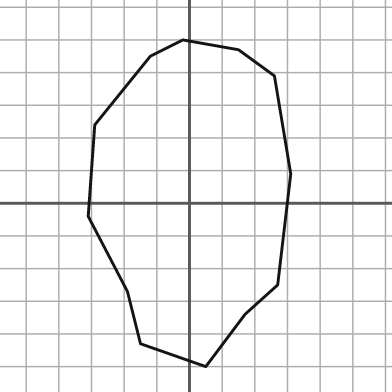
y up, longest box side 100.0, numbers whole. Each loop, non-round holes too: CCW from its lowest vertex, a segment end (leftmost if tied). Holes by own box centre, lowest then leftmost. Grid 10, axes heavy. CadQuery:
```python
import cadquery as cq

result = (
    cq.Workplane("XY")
    .moveTo(5.0, -50.0)
    .lineTo(17.0, -34.0)
    .lineTo(27.0, -25.0)
    .lineTo(31.0, 9.0)
    .lineTo(26.0, 39.0)
    .lineTo(15.0, 47.0)
    .lineTo(-2.0, 50.0)
    .lineTo(-12.0, 45.0)
    .lineTo(-29.0, 24.0)
    .lineTo(-31.0, -4.0)
    .lineTo(-19.0, -27.0)
    .lineTo(-15.0, -43.0)
    .close()
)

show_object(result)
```